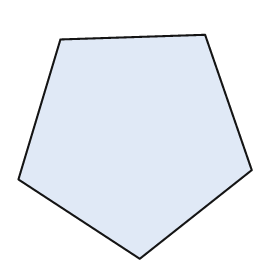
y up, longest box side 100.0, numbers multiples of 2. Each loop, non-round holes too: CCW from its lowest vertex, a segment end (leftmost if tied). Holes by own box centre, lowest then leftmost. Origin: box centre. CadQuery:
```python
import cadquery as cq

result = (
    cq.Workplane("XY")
    .moveTo(2.0, -48.0)
    .lineTo(50.0, -10.0)
    .lineTo(30.0, 48.0)
    .lineTo(-32.0, 46.0)
    .lineTo(-50.0, -14.0)
    .close()
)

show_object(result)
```